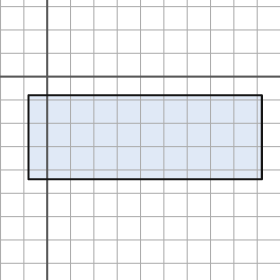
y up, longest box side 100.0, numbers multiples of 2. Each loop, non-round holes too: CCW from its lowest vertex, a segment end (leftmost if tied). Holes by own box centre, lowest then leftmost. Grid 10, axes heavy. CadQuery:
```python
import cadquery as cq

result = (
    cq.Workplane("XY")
    .moveTo(-8.0, -44.0)
    .lineTo(92.0, -44.0)
    .lineTo(92.0, -8.0)
    .lineTo(-8.0, -8.0)
    .close()
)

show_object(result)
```